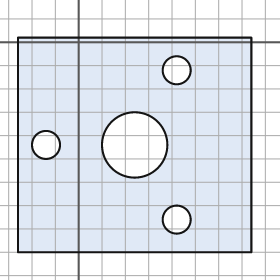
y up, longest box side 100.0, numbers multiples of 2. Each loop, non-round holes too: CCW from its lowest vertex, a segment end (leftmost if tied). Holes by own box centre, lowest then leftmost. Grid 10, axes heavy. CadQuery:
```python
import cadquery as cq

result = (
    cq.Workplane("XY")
    .moveTo(-26.0, -90.0)
    .lineTo(74.0, -90.0)
    .lineTo(74.0, 2.0)
    .lineTo(-26.0, 2.0)
    .close()
    .moveTo(42.0, -76.0)
    .circle(6.0)
    .moveTo(-14.0, -44.0)
    .circle(6.0)
    .moveTo(24.0, -44.0)
    .circle(14.0)
    .moveTo(42.0, -12.0)
    .circle(6.0)
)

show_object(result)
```